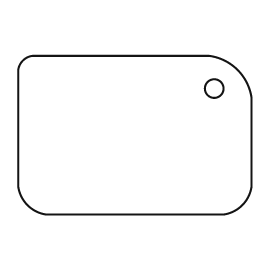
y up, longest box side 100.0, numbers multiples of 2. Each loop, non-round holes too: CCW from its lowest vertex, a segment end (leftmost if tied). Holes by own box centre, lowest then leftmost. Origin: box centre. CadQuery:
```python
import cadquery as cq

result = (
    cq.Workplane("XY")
    .moveTo(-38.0, -34.0)
    .lineTo(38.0, -34.0)
    .threePointArc((46.0, -30.0), (50.0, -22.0))
    .lineTo(50.0, 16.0)
    .threePointArc((44.0, 28.0), (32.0, 34.0))
    .lineTo(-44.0, 34.0)
    .threePointArc((-48.0, 32.0), (-50.0, 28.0))
    .lineTo(-50.0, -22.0)
    .threePointArc((-46.0, -30.0), (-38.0, -34.0))
    .close()
    .moveTo(34.0, 20.0)
    .circle(4.0)
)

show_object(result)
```